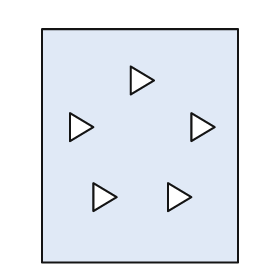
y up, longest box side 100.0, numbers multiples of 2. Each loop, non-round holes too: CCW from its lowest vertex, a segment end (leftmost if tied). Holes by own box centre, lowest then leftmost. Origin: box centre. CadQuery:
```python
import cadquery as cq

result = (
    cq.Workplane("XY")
    .moveTo(-42.0, -50.0)
    .lineTo(42.0, -50.0)
    .lineTo(42.0, 50.0)
    .lineTo(-42.0, 50.0)
    .close()
    .moveTo(-20.0, -28.0)
    .lineTo(-10.0, -22.0)
    .lineTo(-20.0, -16.0)
    .close()
    .moveTo(12.0, -28.0)
    .lineTo(22.0, -22.0)
    .lineTo(12.0, -16.0)
    .close()
    .moveTo(-30.0, 2.0)
    .lineTo(-20.0, 8.0)
    .lineTo(-30.0, 14.0)
    .close()
    .moveTo(22.0, 2.0)
    .lineTo(32.0, 8.0)
    .lineTo(22.0, 14.0)
    .close()
    .moveTo(-4.0, 22.0)
    .lineTo(6.0, 28.0)
    .lineTo(-4.0, 34.0)
    .close()
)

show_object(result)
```